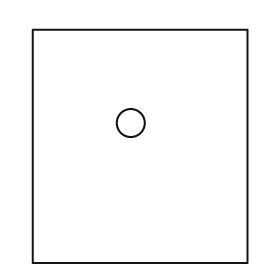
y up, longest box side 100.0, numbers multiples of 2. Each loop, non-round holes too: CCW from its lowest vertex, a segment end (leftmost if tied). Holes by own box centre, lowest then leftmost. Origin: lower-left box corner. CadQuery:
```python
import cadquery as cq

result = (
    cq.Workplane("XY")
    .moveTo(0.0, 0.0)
    .lineTo(92.0, 0.0)
    .lineTo(92.0, 100.0)
    .lineTo(0.0, 100.0)
    .close()
    .moveTo(42.0, 60.0)
    .circle(6.0)
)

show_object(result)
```